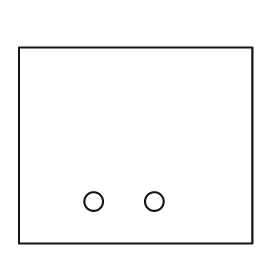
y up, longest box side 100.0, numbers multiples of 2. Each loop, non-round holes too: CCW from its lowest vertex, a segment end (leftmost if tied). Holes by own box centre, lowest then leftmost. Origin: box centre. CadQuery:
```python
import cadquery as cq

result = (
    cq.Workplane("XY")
    .moveTo(-50.0, -42.0)
    .lineTo(50.0, -42.0)
    .lineTo(50.0, 42.0)
    .lineTo(-50.0, 42.0)
    .close()
    .moveTo(-18.0, -24.0)
    .circle(4.0)
    .moveTo(8.0, -24.0)
    .circle(4.0)
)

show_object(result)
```